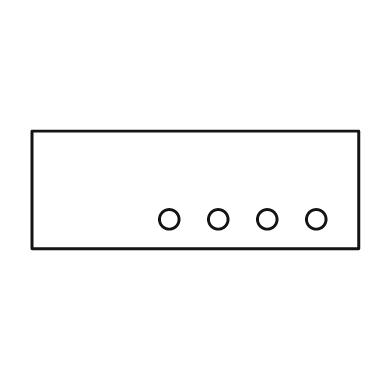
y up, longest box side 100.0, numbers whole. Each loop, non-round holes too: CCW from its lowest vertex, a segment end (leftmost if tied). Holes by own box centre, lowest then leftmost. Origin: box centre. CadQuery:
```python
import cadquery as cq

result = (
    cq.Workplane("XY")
    .moveTo(-50.0, -18.0)
    .lineTo(50.0, -18.0)
    .lineTo(50.0, 18.0)
    .lineTo(-50.0, 18.0)
    .close()
    .moveTo(-8.0, -9.0)
    .circle(3.0)
    .moveTo(7.0, -9.0)
    .circle(3.0)
    .moveTo(22.0, -9.0)
    .circle(3.0)
    .moveTo(37.0, -9.0)
    .circle(3.0)
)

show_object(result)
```